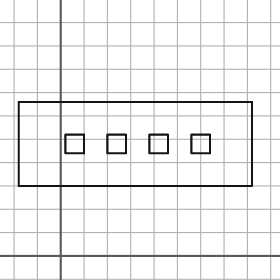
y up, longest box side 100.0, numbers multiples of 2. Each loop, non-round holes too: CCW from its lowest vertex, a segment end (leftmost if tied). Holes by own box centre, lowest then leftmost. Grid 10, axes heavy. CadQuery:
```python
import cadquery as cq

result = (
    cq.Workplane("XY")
    .moveTo(-18.0, 30.0)
    .lineTo(82.0, 30.0)
    .lineTo(82.0, 66.0)
    .lineTo(-18.0, 66.0)
    .close()
    .moveTo(2.0, 44.0)
    .lineTo(10.0, 44.0)
    .lineTo(10.0, 52.0)
    .lineTo(2.0, 52.0)
    .close()
    .moveTo(20.0, 44.0)
    .lineTo(28.0, 44.0)
    .lineTo(28.0, 52.0)
    .lineTo(20.0, 52.0)
    .close()
    .moveTo(38.0, 44.0)
    .lineTo(46.0, 44.0)
    .lineTo(46.0, 52.0)
    .lineTo(38.0, 52.0)
    .close()
    .moveTo(56.0, 44.0)
    .lineTo(64.0, 44.0)
    .lineTo(64.0, 52.0)
    .lineTo(56.0, 52.0)
    .close()
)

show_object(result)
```